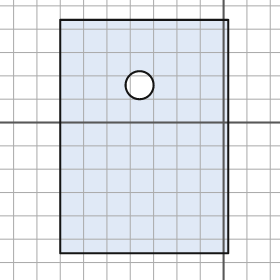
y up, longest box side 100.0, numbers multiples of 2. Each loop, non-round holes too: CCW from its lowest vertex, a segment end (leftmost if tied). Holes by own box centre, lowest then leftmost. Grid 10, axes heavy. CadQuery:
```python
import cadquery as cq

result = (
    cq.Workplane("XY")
    .moveTo(-70.0, -56.0)
    .lineTo(2.0, -56.0)
    .lineTo(2.0, 44.0)
    .lineTo(-70.0, 44.0)
    .close()
    .moveTo(-36.0, 16.0)
    .circle(6.0)
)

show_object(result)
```